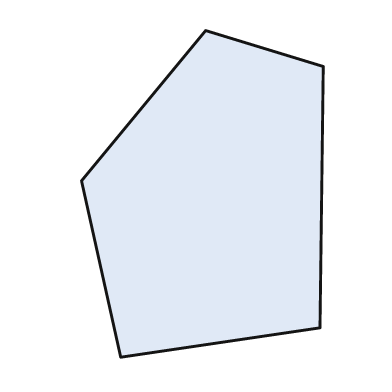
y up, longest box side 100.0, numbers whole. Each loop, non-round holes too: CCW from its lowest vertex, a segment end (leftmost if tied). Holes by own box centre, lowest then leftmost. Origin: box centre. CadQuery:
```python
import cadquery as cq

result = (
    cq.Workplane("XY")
    .moveTo(-25.0, -50.0)
    .lineTo(36.0, -41.0)
    .lineTo(37.0, 39.0)
    .lineTo(1.0, 50.0)
    .lineTo(-37.0, 4.0)
    .close()
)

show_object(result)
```